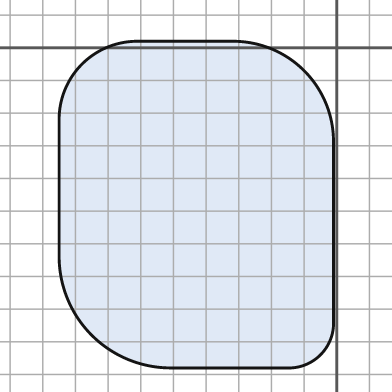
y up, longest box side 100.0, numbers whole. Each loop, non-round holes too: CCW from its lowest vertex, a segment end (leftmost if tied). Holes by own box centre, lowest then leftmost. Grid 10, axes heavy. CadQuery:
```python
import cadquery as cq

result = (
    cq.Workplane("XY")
    .moveTo(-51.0, -98.0)
    .lineTo(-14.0, -98.0)
    .threePointArc((-5.0, -94.0), (-1.0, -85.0))
    .lineTo(-1.0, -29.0)
    .threePointArc((-10.0, -7.0), (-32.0, 2.0))
    .lineTo(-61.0, 2.0)
    .threePointArc((-78.0, -5.0), (-85.0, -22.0))
    .lineTo(-85.0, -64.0)
    .threePointArc((-75.0, -88.0), (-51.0, -98.0))
    .close()
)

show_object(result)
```